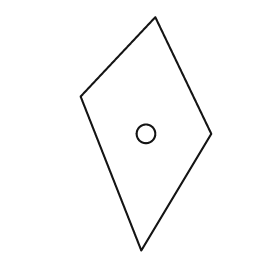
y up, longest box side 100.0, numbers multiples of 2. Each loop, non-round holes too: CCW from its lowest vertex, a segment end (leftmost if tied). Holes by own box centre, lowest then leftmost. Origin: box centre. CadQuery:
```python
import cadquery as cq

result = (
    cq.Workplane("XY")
    .moveTo(-2.0, -50.0)
    .lineTo(28.0, 0.0)
    .lineTo(4.0, 50.0)
    .lineTo(-28.0, 16.0)
    .close()
    .moveTo(0.0, 0.0)
    .circle(4.0)
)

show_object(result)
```